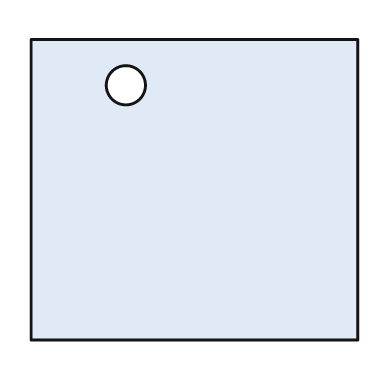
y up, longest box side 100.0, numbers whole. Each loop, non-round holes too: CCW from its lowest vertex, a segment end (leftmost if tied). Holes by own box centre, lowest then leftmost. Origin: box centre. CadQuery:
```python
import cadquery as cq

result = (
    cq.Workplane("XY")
    .moveTo(-50.0, -46.0)
    .lineTo(50.0, -46.0)
    .lineTo(50.0, 46.0)
    .lineTo(-50.0, 46.0)
    .close()
    .moveTo(-21.0, 32.0)
    .circle(6.0)
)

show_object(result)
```